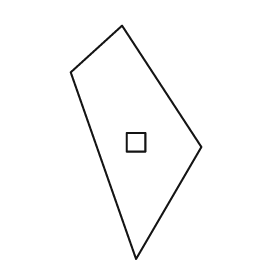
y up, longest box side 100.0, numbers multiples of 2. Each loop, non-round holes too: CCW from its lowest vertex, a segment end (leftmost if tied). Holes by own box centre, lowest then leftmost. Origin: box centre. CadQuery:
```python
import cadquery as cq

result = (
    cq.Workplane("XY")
    .moveTo(0.0, -50.0)
    .lineTo(28.0, -2.0)
    .lineTo(-6.0, 50.0)
    .lineTo(-28.0, 30.0)
    .close()
    .moveTo(-4.0, -4.0)
    .lineTo(4.0, -4.0)
    .lineTo(4.0, 4.0)
    .lineTo(-4.0, 4.0)
    .close()
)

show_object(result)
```